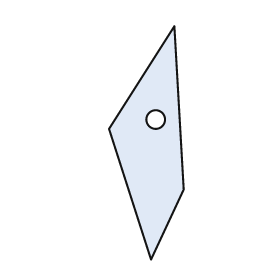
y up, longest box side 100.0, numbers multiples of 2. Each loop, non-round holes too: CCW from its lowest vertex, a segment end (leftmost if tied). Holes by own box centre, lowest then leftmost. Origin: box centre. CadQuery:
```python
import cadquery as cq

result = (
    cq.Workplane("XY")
    .moveTo(2.0, -50.0)
    .lineTo(16.0, -20.0)
    .lineTo(12.0, 50.0)
    .lineTo(-16.0, 6.0)
    .close()
    .moveTo(4.0, 10.0)
    .circle(4.0)
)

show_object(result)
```